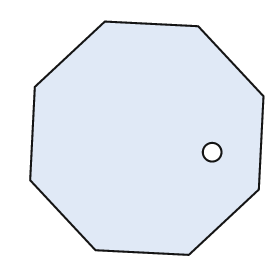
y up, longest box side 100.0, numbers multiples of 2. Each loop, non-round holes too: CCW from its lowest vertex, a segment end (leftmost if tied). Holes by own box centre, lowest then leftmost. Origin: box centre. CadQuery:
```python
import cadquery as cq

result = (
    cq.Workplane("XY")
    .moveTo(18.0, -50.0)
    .lineTo(48.0, -22.0)
    .lineTo(50.0, 18.0)
    .lineTo(22.0, 48.0)
    .lineTo(-18.0, 50.0)
    .lineTo(-48.0, 22.0)
    .lineTo(-50.0, -18.0)
    .lineTo(-22.0, -48.0)
    .close()
    .moveTo(28.0, -6.0)
    .circle(4.0)
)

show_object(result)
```